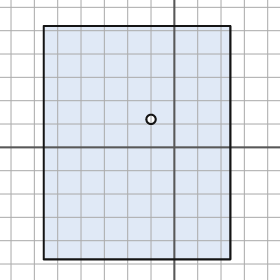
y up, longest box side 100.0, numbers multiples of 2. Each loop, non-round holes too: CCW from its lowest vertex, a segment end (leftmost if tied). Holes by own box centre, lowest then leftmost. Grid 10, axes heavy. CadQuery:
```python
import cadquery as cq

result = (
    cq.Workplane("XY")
    .moveTo(-56.0, -48.0)
    .lineTo(24.0, -48.0)
    .lineTo(24.0, 52.0)
    .lineTo(-56.0, 52.0)
    .close()
    .moveTo(-10.0, 12.0)
    .circle(2.0)
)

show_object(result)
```